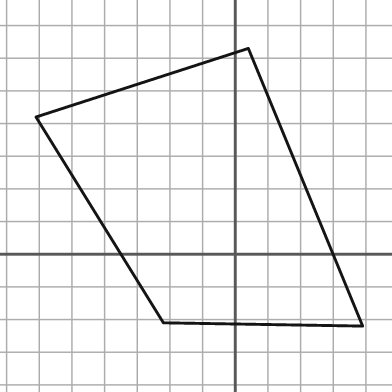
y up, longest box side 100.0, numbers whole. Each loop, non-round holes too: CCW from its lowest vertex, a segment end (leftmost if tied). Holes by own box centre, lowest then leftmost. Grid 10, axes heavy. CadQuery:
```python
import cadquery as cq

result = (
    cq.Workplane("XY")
    .moveTo(39.0, -22.0)
    .lineTo(4.0, 63.0)
    .lineTo(-61.0, 42.0)
    .lineTo(-22.0, -21.0)
    .close()
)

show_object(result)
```